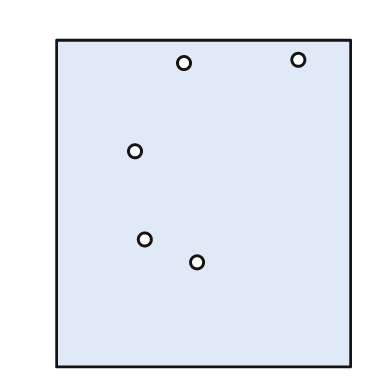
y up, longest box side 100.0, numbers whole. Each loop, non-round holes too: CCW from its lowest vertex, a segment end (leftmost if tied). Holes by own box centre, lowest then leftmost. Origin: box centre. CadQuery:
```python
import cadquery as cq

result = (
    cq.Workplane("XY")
    .moveTo(-45.0, -50.0)
    .lineTo(45.0, -50.0)
    .lineTo(45.0, 50.0)
    .lineTo(-45.0, 50.0)
    .close()
    .moveTo(-2.0, -18.0)
    .circle(2.0)
    .moveTo(-18.0, -11.0)
    .circle(2.0)
    .moveTo(-21.0, 16.0)
    .circle(2.0)
    .moveTo(-6.0, 43.0)
    .circle(2.0)
    .moveTo(29.0, 44.0)
    .circle(2.0)
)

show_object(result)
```